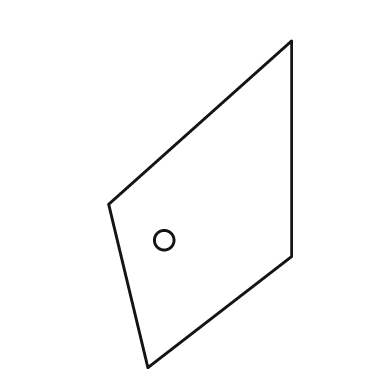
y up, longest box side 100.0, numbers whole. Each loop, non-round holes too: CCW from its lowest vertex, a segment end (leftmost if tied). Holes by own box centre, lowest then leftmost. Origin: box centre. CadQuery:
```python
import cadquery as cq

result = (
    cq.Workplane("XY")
    .moveTo(-16.0, -50.0)
    .lineTo(28.0, -16.0)
    .lineTo(28.0, 50.0)
    .lineTo(-28.0, 0.0)
    .close()
    .moveTo(-11.0, -11.0)
    .circle(3.0)
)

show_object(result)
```